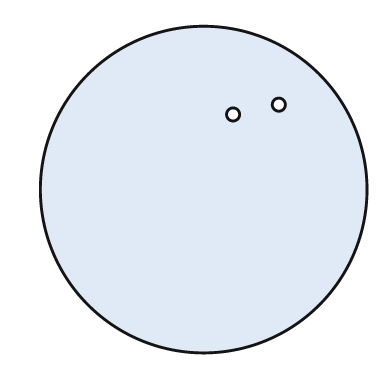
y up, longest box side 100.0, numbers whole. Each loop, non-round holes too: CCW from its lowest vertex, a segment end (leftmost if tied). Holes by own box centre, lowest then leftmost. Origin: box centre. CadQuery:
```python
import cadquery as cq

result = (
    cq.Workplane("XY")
    .moveTo(0.0, 0.0)
    .circle(50.0)
    .moveTo(9.0, 23.0)
    .circle(2.0)
    .moveTo(23.0, 26.0)
    .circle(2.0)
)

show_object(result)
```